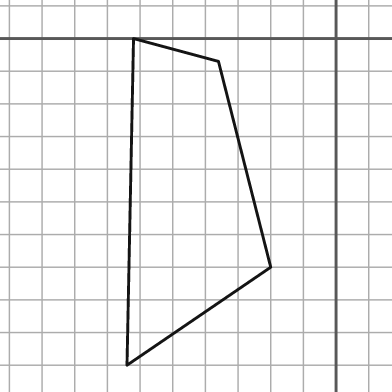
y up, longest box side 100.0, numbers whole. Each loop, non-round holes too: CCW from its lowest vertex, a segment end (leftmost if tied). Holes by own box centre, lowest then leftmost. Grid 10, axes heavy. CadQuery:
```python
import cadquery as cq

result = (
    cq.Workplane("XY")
    .moveTo(-64.0, -100.0)
    .lineTo(-20.0, -70.0)
    .lineTo(-36.0, -7.0)
    .lineTo(-62.0, 0.0)
    .close()
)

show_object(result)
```